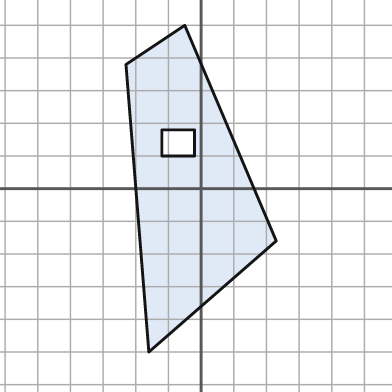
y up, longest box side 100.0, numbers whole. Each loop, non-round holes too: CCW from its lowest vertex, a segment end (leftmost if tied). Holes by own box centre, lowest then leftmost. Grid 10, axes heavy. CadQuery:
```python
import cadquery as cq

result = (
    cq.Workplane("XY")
    .moveTo(-16.0, -50.0)
    .lineTo(23.0, -16.0)
    .lineTo(-5.0, 50.0)
    .lineTo(-23.0, 38.0)
    .close()
    .moveTo(-12.0, 10.0)
    .lineTo(-2.0, 10.0)
    .lineTo(-2.0, 18.0)
    .lineTo(-12.0, 18.0)
    .close()
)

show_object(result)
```